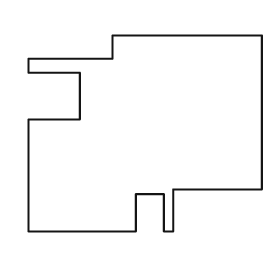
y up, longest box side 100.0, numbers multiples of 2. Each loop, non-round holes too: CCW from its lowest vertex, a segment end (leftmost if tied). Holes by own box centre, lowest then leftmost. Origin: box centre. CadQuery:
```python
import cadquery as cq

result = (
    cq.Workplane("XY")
    .moveTo(-50.0, -42.0)
    .lineTo(-4.0, -42.0)
    .lineTo(-4.0, -26.0)
    .lineTo(8.0, -26.0)
    .lineTo(8.0, -42.0)
    .lineTo(12.0, -42.0)
    .lineTo(12.0, -24.0)
    .lineTo(50.0, -24.0)
    .lineTo(50.0, 42.0)
    .lineTo(-14.0, 42.0)
    .lineTo(-14.0, 32.0)
    .lineTo(-50.0, 32.0)
    .lineTo(-50.0, 26.0)
    .lineTo(-28.0, 26.0)
    .lineTo(-28.0, 6.0)
    .lineTo(-50.0, 6.0)
    .close()
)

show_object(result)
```